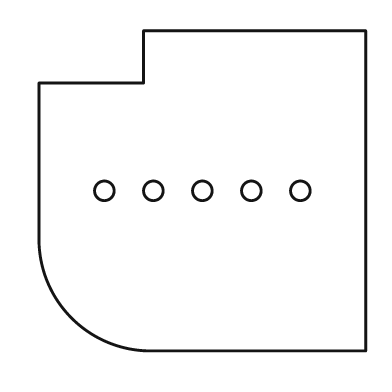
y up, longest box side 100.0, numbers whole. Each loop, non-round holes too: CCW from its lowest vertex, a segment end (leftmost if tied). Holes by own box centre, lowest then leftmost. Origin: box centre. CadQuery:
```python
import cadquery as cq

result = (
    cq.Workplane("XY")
    .moveTo(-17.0, -49.0)
    .lineTo(50.0, -49.0)
    .lineTo(50.0, 49.0)
    .lineTo(-18.0, 49.0)
    .lineTo(-18.0, 33.0)
    .lineTo(-50.0, 33.0)
    .lineTo(-50.0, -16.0)
    .threePointArc((-40.0, -39.0), (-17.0, -49.0))
    .close()
    .moveTo(-30.0, 0.0)
    .circle(3.0)
    .moveTo(-15.0, 0.0)
    .circle(3.0)
    .moveTo(0.0, 0.0)
    .circle(3.0)
    .moveTo(15.0, 0.0)
    .circle(3.0)
    .moveTo(30.0, 0.0)
    .circle(3.0)
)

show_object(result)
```